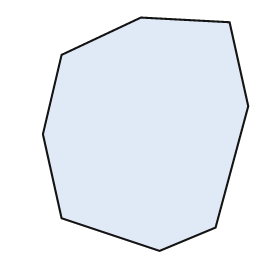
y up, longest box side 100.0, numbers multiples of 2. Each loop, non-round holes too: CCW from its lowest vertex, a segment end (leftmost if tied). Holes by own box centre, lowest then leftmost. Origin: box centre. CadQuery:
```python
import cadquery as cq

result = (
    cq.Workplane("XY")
    .moveTo(6.0, -50.0)
    .lineTo(30.0, -40.0)
    .lineTo(44.0, 12.0)
    .lineTo(36.0, 48.0)
    .lineTo(-2.0, 50.0)
    .lineTo(-36.0, 34.0)
    .lineTo(-44.0, 0.0)
    .lineTo(-36.0, -36.0)
    .close()
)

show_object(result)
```